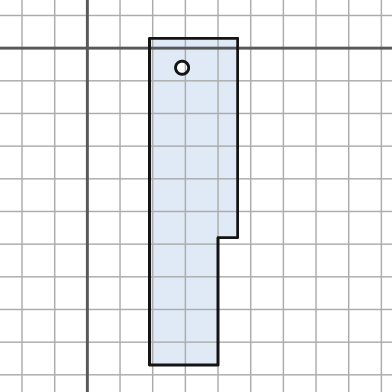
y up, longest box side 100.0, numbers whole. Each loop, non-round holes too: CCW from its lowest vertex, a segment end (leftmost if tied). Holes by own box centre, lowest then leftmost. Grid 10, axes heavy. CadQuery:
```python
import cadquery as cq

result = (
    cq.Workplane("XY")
    .moveTo(19.0, -97.0)
    .lineTo(40.0, -97.0)
    .lineTo(40.0, -58.0)
    .lineTo(46.0, -58.0)
    .lineTo(46.0, 3.0)
    .lineTo(19.0, 3.0)
    .close()
    .moveTo(29.0, -6.0)
    .circle(2.0)
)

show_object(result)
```